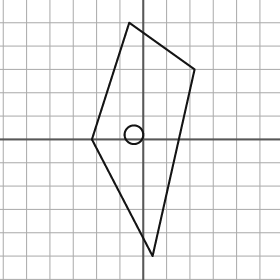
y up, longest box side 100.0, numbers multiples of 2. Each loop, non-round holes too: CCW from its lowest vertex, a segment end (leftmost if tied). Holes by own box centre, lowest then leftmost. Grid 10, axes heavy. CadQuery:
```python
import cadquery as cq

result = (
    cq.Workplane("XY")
    .moveTo(4.0, -50.0)
    .lineTo(22.0, 30.0)
    .lineTo(-6.0, 50.0)
    .lineTo(-22.0, 0.0)
    .close()
    .moveTo(-4.0, 2.0)
    .circle(4.0)
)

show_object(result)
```